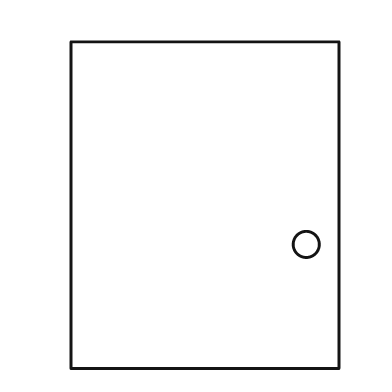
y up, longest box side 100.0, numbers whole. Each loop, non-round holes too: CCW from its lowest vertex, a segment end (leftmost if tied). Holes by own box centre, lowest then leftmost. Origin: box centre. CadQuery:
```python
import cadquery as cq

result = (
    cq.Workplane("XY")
    .moveTo(-41.0, -50.0)
    .lineTo(41.0, -50.0)
    .lineTo(41.0, 50.0)
    .lineTo(-41.0, 50.0)
    .close()
    .moveTo(31.0, -12.0)
    .circle(4.0)
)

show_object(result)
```